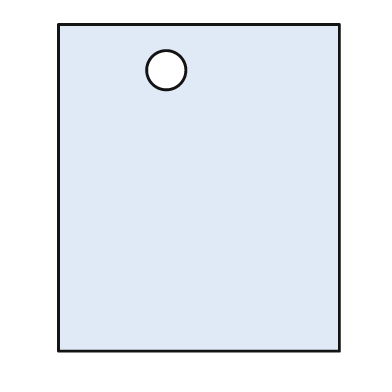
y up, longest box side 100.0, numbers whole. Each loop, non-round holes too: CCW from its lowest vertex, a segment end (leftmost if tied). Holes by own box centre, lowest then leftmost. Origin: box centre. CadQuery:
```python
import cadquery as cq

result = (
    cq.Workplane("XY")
    .moveTo(-43.0, -50.0)
    .lineTo(43.0, -50.0)
    .lineTo(43.0, 50.0)
    .lineTo(-43.0, 50.0)
    .close()
    .moveTo(-10.0, 36.0)
    .circle(6.0)
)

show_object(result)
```